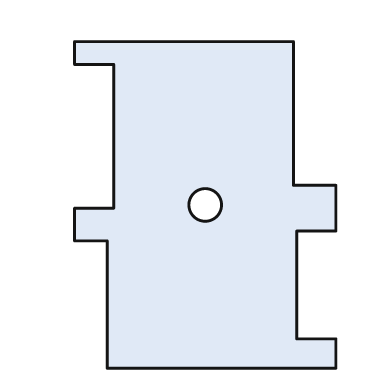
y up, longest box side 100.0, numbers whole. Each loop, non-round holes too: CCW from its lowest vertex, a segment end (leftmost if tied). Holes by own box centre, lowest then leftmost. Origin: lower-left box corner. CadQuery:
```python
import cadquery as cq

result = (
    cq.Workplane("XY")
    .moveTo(10.0, 0.0)
    .lineTo(80.0, 0.0)
    .lineTo(80.0, 9.0)
    .lineTo(68.0, 9.0)
    .lineTo(68.0, 42.0)
    .lineTo(80.0, 42.0)
    .lineTo(80.0, 56.0)
    .lineTo(67.0, 56.0)
    .lineTo(67.0, 100.0)
    .lineTo(0.0, 100.0)
    .lineTo(0.0, 93.0)
    .lineTo(12.0, 93.0)
    .lineTo(12.0, 49.0)
    .lineTo(0.0, 49.0)
    .lineTo(0.0, 39.0)
    .lineTo(10.0, 39.0)
    .close()
    .moveTo(40.0, 50.0)
    .circle(5.0)
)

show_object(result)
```